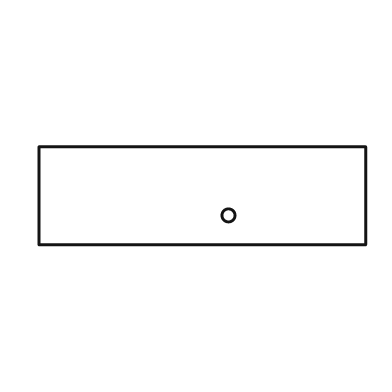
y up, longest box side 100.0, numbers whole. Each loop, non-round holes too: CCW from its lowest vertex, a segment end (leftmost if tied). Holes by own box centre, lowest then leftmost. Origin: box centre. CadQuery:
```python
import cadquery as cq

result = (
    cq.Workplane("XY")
    .moveTo(-50.0, -15.0)
    .lineTo(50.0, -15.0)
    .lineTo(50.0, 15.0)
    .lineTo(-50.0, 15.0)
    .close()
    .moveTo(8.0, -6.0)
    .circle(2.0)
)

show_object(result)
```